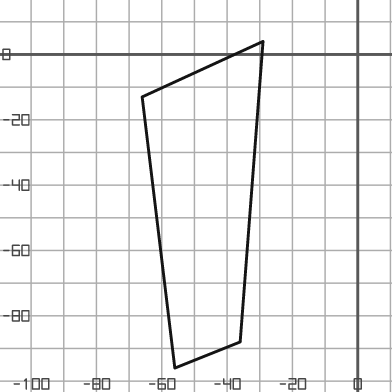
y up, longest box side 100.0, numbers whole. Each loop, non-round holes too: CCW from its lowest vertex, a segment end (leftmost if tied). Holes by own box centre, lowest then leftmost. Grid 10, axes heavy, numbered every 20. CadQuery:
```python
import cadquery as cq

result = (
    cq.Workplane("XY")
    .moveTo(-56.0, -96.0)
    .lineTo(-36.0, -88.0)
    .lineTo(-29.0, 4.0)
    .lineTo(-66.0, -13.0)
    .close()
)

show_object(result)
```